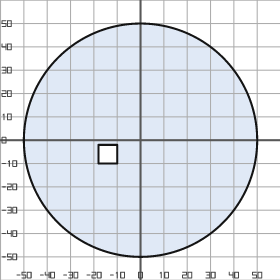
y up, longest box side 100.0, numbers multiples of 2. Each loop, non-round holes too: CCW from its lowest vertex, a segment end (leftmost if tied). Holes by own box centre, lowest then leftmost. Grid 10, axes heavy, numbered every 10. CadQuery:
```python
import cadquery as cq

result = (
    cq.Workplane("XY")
    .moveTo(0.0, 0.0)
    .circle(50.0)
    .moveTo(-18.0, -10.0)
    .lineTo(-10.0, -10.0)
    .lineTo(-10.0, -2.0)
    .lineTo(-18.0, -2.0)
    .close()
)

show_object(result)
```